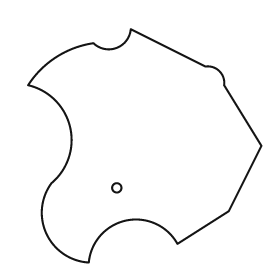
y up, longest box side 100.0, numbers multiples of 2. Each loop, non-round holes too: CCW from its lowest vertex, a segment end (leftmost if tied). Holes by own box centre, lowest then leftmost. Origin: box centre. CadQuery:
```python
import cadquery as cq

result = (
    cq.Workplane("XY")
    .moveTo(-24.0, -50.0)
    .threePointArc((-8.0, -32.0), (14.0, -42.0))
    .lineTo(36.0, -28.0)
    .lineTo(50.0, 0.0)
    .lineTo(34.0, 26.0)
    .threePointArc((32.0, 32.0), (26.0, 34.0))
    .lineTo(-6.0, 50.0)
    .threePointArc((-12.0, 42.0), (-22.0, 44.0))
    .threePointArc((-38.0, 38.0), (-50.0, 26.0))
    .threePointArc((-32.0, 8.0), (-40.0, -16.0))
    .threePointArc((-42.0, -38.0), (-24.0, -50.0))
    .close()
    .moveTo(-12.0, -18.0)
    .circle(2.0)
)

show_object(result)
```